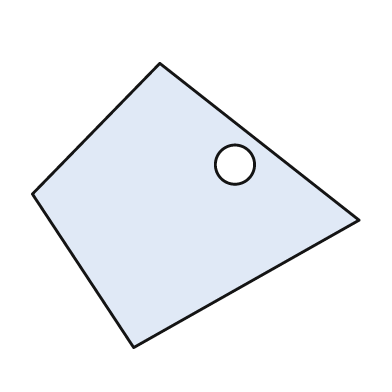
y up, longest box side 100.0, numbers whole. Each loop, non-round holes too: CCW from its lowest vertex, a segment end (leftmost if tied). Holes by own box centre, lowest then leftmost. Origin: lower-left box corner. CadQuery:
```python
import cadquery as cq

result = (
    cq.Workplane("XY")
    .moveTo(31.0, 0.0)
    .lineTo(100.0, 39.0)
    .lineTo(39.0, 87.0)
    .lineTo(0.0, 47.0)
    .close()
    .moveTo(62.0, 56.0)
    .circle(6.0)
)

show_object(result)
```